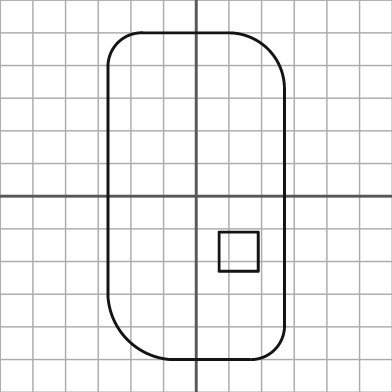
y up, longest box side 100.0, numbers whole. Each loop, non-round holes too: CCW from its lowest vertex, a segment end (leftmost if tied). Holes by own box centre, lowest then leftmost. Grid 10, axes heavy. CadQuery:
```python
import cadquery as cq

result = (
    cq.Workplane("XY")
    .moveTo(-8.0, -50.0)
    .lineTo(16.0, -50.0)
    .threePointArc((24.0, -47.0), (27.0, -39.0))
    .lineTo(27.0, 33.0)
    .threePointArc((22.0, 45.0), (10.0, 50.0))
    .lineTo(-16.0, 50.0)
    .threePointArc((-24.0, 47.0), (-27.0, 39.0))
    .lineTo(-27.0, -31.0)
    .threePointArc((-21.0, -44.0), (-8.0, -50.0))
    .close()
    .moveTo(7.0, -23.0)
    .lineTo(19.0, -23.0)
    .lineTo(19.0, -11.0)
    .lineTo(7.0, -11.0)
    .close()
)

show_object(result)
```